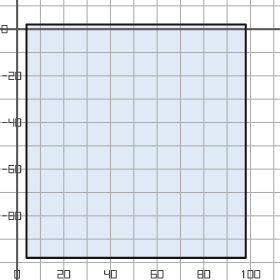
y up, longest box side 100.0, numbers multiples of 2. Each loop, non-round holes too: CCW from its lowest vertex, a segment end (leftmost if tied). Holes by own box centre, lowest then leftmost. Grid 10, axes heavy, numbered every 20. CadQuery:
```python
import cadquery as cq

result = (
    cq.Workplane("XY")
    .moveTo(4.0, -98.0)
    .lineTo(98.0, -98.0)
    .lineTo(98.0, 2.0)
    .lineTo(4.0, 2.0)
    .close()
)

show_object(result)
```